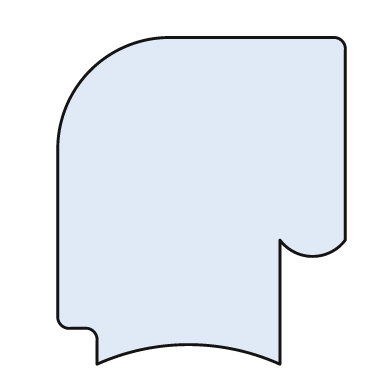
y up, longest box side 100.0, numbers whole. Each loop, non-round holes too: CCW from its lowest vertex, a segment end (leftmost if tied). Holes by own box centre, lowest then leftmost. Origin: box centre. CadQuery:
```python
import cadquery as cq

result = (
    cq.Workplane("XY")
    .moveTo(-32.0, -50.0)
    .threePointArc((-4.0, -44.0), (24.0, -50.0))
    .lineTo(24.0, -12.0)
    .threePointArc((34.0, -17.0), (44.0, -12.0))
    .lineTo(44.0, 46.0)
    .threePointArc((43.0, 49.0), (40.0, 50.0))
    .lineTo(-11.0, 50.0)
    .threePointArc((-34.0, 40.0), (-44.0, 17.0))
    .lineTo(-44.0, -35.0)
    .threePointArc((-43.0, -38.0), (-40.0, -39.0))
    .lineTo(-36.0, -39.0)
    .threePointArc((-33.0, -40.0), (-32.0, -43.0))
    .close()
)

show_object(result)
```